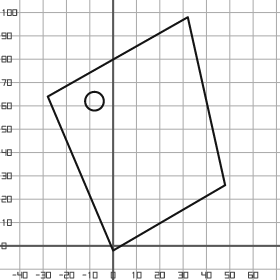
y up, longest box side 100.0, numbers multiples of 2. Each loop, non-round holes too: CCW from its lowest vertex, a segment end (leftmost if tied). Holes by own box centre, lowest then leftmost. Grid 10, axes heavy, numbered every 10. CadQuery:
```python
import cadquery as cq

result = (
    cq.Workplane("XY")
    .moveTo(0.0, -2.0)
    .lineTo(48.0, 26.0)
    .lineTo(32.0, 98.0)
    .lineTo(-28.0, 64.0)
    .close()
    .moveTo(-8.0, 62.0)
    .circle(4.0)
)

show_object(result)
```